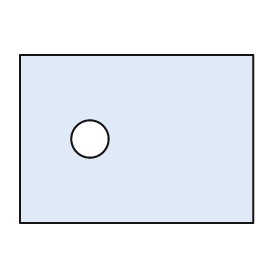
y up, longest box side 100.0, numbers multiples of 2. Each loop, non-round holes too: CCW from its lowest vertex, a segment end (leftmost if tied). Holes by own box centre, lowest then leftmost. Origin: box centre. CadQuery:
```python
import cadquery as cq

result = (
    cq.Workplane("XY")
    .moveTo(-50.0, -36.0)
    .lineTo(50.0, -36.0)
    .lineTo(50.0, 36.0)
    .lineTo(-50.0, 36.0)
    .close()
    .moveTo(-20.0, 0.0)
    .circle(8.0)
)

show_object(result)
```